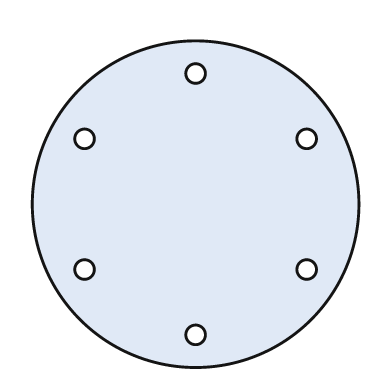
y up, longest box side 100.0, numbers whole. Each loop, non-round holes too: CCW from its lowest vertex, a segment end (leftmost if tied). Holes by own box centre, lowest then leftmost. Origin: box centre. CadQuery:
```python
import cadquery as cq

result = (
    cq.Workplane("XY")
    .moveTo(0.0, 0.0)
    .circle(50.0)
    .moveTo(0.0, -40.0)
    .circle(3.0)
    .moveTo(-34.0, -20.0)
    .circle(3.0)
    .moveTo(34.0, -20.0)
    .circle(3.0)
    .moveTo(-34.0, 20.0)
    .circle(3.0)
    .moveTo(34.0, 20.0)
    .circle(3.0)
    .moveTo(0.0, 40.0)
    .circle(3.0)
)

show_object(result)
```